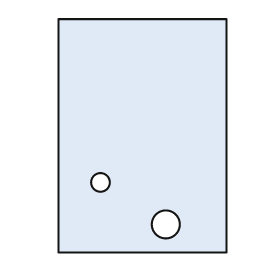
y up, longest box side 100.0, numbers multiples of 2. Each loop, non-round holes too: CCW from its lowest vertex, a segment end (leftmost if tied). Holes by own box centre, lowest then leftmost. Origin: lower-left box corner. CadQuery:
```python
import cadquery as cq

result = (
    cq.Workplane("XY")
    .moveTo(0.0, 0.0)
    .lineTo(72.0, 0.0)
    .lineTo(72.0, 100.0)
    .lineTo(0.0, 100.0)
    .close()
    .moveTo(46.0, 12.0)
    .circle(6.0)
    .moveTo(18.0, 30.0)
    .circle(4.0)
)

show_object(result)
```